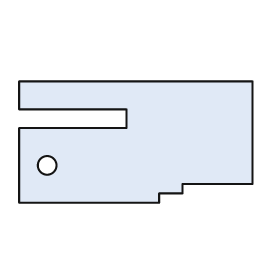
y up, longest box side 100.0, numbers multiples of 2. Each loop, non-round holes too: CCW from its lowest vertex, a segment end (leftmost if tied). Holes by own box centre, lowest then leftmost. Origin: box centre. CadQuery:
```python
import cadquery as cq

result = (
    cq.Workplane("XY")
    .moveTo(-50.0, -26.0)
    .lineTo(10.0, -26.0)
    .lineTo(10.0, -22.0)
    .lineTo(20.0, -22.0)
    .lineTo(20.0, -18.0)
    .lineTo(50.0, -18.0)
    .lineTo(50.0, 26.0)
    .lineTo(-50.0, 26.0)
    .lineTo(-50.0, 14.0)
    .lineTo(-4.0, 14.0)
    .lineTo(-4.0, 6.0)
    .lineTo(-50.0, 6.0)
    .close()
    .moveTo(-38.0, -10.0)
    .circle(4.0)
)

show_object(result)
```